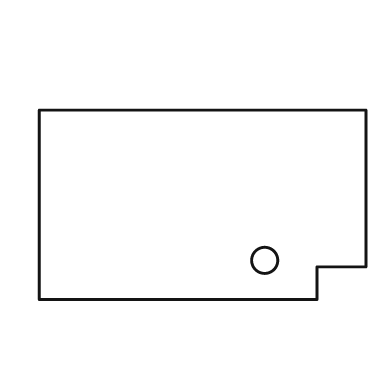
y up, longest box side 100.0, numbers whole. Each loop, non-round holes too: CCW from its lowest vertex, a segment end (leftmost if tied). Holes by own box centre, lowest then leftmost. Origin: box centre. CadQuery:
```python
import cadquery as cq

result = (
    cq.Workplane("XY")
    .moveTo(-50.0, -29.0)
    .lineTo(35.0, -29.0)
    .lineTo(35.0, -19.0)
    .lineTo(50.0, -19.0)
    .lineTo(50.0, 29.0)
    .lineTo(-50.0, 29.0)
    .close()
    .moveTo(19.0, -17.0)
    .circle(4.0)
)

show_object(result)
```